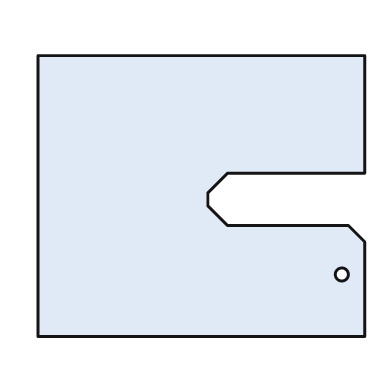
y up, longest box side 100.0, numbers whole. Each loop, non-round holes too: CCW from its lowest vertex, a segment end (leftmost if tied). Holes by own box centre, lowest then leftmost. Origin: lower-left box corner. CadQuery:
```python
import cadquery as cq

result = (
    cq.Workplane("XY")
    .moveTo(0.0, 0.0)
    .lineTo(100.0, 0.0)
    .lineTo(100.0, 29.0)
    .lineTo(95.0, 34.0)
    .lineTo(58.0, 34.0)
    .lineTo(52.0, 40.0)
    .lineTo(52.0, 44.0)
    .lineTo(58.0, 50.0)
    .lineTo(100.0, 50.0)
    .lineTo(100.0, 86.0)
    .lineTo(0.0, 86.0)
    .close()
    .moveTo(93.0, 19.0)
    .circle(2.0)
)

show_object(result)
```